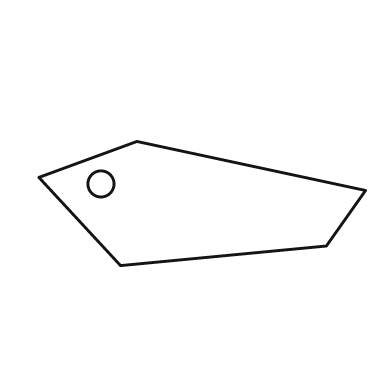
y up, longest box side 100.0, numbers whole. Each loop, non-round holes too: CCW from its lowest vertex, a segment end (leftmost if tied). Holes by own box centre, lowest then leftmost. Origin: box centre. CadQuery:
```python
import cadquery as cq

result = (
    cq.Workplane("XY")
    .moveTo(-25.0, -19.0)
    .lineTo(38.0, -13.0)
    .lineTo(50.0, 4.0)
    .lineTo(-20.0, 19.0)
    .lineTo(-50.0, 8.0)
    .close()
    .moveTo(-31.0, 6.0)
    .circle(4.0)
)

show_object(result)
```